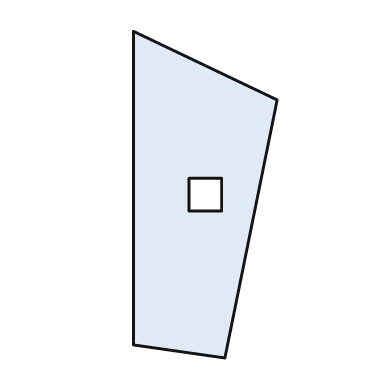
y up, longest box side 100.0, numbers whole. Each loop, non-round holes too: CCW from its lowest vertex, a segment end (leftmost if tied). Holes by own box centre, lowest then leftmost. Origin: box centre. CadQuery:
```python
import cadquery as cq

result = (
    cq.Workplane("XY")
    .moveTo(6.0, -50.0)
    .lineTo(22.0, 29.0)
    .lineTo(-22.0, 50.0)
    .lineTo(-22.0, -46.0)
    .close()
    .moveTo(-5.0, -5.0)
    .lineTo(5.0, -5.0)
    .lineTo(5.0, 5.0)
    .lineTo(-5.0, 5.0)
    .close()
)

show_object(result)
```